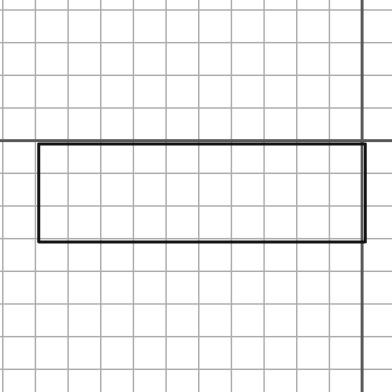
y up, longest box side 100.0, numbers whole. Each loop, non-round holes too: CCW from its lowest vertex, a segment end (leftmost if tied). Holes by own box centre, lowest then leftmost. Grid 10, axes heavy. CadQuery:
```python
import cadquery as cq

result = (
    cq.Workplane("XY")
    .moveTo(-99.0, -31.0)
    .lineTo(1.0, -31.0)
    .lineTo(1.0, -1.0)
    .lineTo(-99.0, -1.0)
    .close()
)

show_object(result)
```